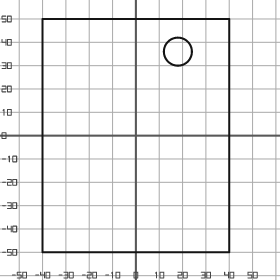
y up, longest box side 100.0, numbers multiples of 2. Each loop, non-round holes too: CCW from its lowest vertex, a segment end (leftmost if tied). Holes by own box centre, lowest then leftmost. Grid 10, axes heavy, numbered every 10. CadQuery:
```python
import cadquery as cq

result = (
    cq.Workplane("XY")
    .moveTo(-40.0, -50.0)
    .lineTo(40.0, -50.0)
    .lineTo(40.0, 50.0)
    .lineTo(-40.0, 50.0)
    .close()
    .moveTo(18.0, 36.0)
    .circle(6.0)
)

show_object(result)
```